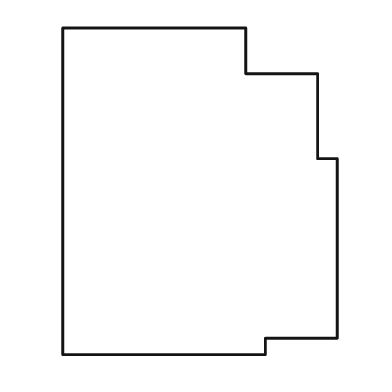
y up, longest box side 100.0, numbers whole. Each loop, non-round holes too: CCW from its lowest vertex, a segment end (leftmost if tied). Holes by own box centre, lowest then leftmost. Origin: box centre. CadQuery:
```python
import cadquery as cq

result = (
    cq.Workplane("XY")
    .moveTo(-42.0, -50.0)
    .lineTo(20.0, -50.0)
    .lineTo(20.0, -45.0)
    .lineTo(42.0, -45.0)
    .lineTo(42.0, 10.0)
    .lineTo(36.0, 10.0)
    .lineTo(36.0, 36.0)
    .lineTo(14.0, 36.0)
    .lineTo(14.0, 50.0)
    .lineTo(-42.0, 50.0)
    .close()
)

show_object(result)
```